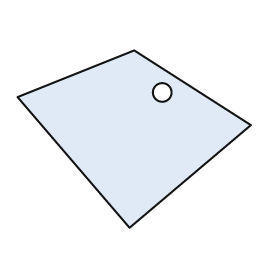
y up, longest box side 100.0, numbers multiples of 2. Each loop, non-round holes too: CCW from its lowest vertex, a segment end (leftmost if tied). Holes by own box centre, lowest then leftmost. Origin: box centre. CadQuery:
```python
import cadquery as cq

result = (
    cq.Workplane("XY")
    .moveTo(-2.0, -38.0)
    .lineTo(50.0, 6.0)
    .lineTo(0.0, 38.0)
    .lineTo(-50.0, 18.0)
    .close()
    .moveTo(12.0, 20.0)
    .circle(4.0)
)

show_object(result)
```